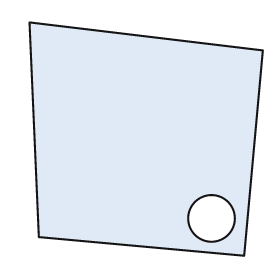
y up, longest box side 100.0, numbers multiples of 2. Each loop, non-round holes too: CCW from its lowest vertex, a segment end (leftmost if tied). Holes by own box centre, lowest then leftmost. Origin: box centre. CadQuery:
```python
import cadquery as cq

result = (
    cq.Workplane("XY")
    .moveTo(42.0, -50.0)
    .lineTo(50.0, 38.0)
    .lineTo(-50.0, 50.0)
    .lineTo(-46.0, -42.0)
    .close()
    .moveTo(28.0, -34.0)
    .circle(10.0)
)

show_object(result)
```